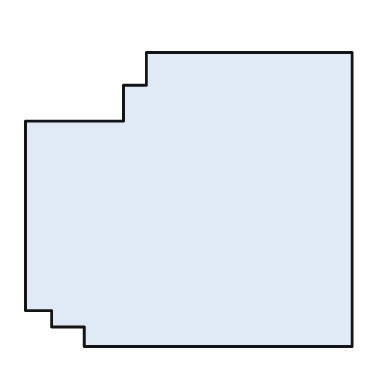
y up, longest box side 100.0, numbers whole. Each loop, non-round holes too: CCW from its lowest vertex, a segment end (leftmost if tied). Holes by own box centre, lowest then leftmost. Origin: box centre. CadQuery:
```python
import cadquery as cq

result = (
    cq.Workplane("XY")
    .moveTo(-32.0, -45.0)
    .lineTo(50.0, -45.0)
    .lineTo(50.0, 45.0)
    .lineTo(-13.0, 45.0)
    .lineTo(-13.0, 35.0)
    .lineTo(-20.0, 35.0)
    .lineTo(-20.0, 24.0)
    .lineTo(-50.0, 24.0)
    .lineTo(-50.0, -34.0)
    .lineTo(-42.0, -34.0)
    .lineTo(-42.0, -39.0)
    .lineTo(-32.0, -39.0)
    .close()
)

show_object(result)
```